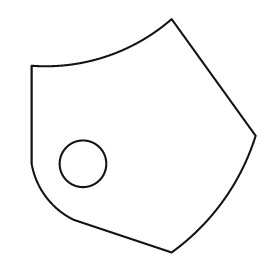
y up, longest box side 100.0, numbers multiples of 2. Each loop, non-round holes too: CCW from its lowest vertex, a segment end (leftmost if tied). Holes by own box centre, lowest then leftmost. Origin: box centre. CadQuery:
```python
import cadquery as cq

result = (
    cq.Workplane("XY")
    .moveTo(12.0, -50.0)
    .threePointArc((34.0, -28.0), (48.0, 0.0))
    .lineTo(12.0, 50.0)
    .threePointArc((-16.0, 34.0), (-48.0, 30.0))
    .lineTo(-48.0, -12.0)
    .threePointArc((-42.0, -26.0), (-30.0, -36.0))
    .close()
    .moveTo(-26.0, -12.0)
    .circle(10.0)
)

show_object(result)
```